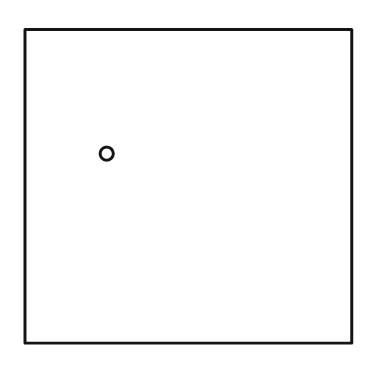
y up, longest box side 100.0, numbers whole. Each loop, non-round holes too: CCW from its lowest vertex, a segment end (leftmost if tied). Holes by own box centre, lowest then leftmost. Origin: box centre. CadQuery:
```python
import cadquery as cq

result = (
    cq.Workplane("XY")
    .moveTo(-50.0, -48.0)
    .lineTo(50.0, -48.0)
    .lineTo(50.0, 48.0)
    .lineTo(-50.0, 48.0)
    .close()
    .moveTo(-25.0, 10.0)
    .circle(2.0)
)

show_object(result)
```